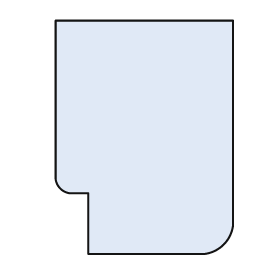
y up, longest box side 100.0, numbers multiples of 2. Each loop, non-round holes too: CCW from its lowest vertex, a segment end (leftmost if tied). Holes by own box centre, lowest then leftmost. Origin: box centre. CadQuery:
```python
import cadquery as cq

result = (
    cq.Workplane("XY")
    .moveTo(-24.0, -50.0)
    .lineTo(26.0, -50.0)
    .threePointArc((34.0, -46.0), (38.0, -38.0))
    .lineTo(38.0, 50.0)
    .lineTo(-38.0, 50.0)
    .lineTo(-38.0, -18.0)
    .threePointArc((-36.0, -22.0), (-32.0, -24.0))
    .lineTo(-24.0, -24.0)
    .close()
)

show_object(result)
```